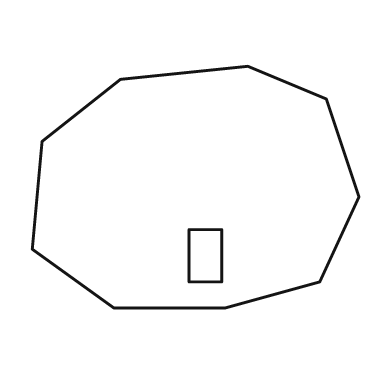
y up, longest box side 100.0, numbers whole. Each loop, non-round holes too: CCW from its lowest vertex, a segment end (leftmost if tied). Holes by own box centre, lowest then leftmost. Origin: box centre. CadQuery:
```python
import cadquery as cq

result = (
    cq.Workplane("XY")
    .moveTo(-25.0, -37.0)
    .lineTo(9.0, -37.0)
    .lineTo(38.0, -29.0)
    .lineTo(50.0, -3.0)
    .lineTo(40.0, 27.0)
    .lineTo(16.0, 37.0)
    .lineTo(-23.0, 33.0)
    .lineTo(-47.0, 14.0)
    .lineTo(-50.0, -19.0)
    .close()
    .moveTo(-2.0, -29.0)
    .lineTo(8.0, -29.0)
    .lineTo(8.0, -13.0)
    .lineTo(-2.0, -13.0)
    .close()
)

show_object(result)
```